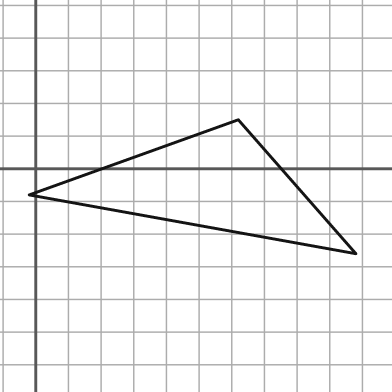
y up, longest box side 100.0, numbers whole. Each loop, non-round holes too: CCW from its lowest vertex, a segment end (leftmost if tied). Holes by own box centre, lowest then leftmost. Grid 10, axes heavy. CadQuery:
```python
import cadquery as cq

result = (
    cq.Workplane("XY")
    .moveTo(98.0, -26.0)
    .lineTo(62.0, 15.0)
    .lineTo(-2.0, -8.0)
    .close()
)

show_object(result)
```